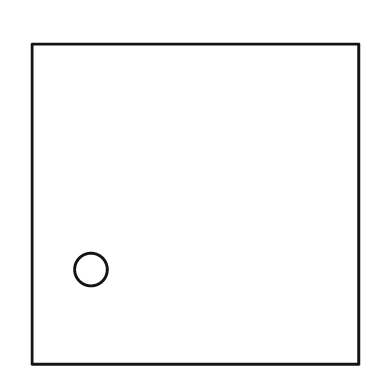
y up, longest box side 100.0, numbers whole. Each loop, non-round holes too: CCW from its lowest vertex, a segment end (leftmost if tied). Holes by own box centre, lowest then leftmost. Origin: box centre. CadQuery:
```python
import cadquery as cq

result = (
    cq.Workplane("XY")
    .moveTo(-50.0, -49.0)
    .lineTo(50.0, -49.0)
    .lineTo(50.0, 49.0)
    .lineTo(-50.0, 49.0)
    .close()
    .moveTo(-32.0, -20.0)
    .circle(5.0)
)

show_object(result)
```